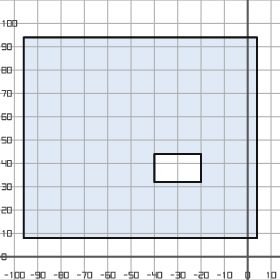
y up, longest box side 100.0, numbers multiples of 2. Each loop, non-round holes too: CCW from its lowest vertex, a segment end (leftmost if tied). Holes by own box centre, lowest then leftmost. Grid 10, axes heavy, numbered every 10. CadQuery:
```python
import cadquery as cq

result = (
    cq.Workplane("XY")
    .moveTo(-96.0, 8.0)
    .lineTo(4.0, 8.0)
    .lineTo(4.0, 94.0)
    .lineTo(-96.0, 94.0)
    .close()
    .moveTo(-40.0, 32.0)
    .lineTo(-20.0, 32.0)
    .lineTo(-20.0, 44.0)
    .lineTo(-40.0, 44.0)
    .close()
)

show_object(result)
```